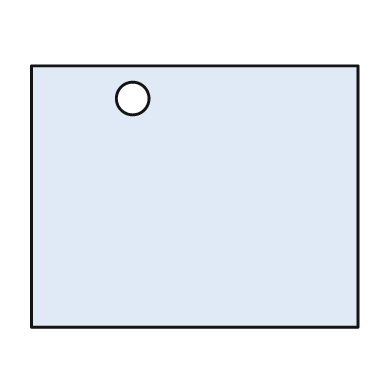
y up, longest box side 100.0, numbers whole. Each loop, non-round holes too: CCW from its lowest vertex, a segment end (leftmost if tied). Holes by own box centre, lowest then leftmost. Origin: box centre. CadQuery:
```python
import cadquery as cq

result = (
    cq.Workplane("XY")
    .moveTo(-50.0, -40.0)
    .lineTo(50.0, -40.0)
    .lineTo(50.0, 40.0)
    .lineTo(-50.0, 40.0)
    .close()
    .moveTo(-19.0, 30.0)
    .circle(5.0)
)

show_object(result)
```